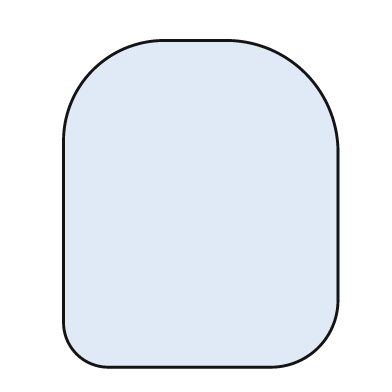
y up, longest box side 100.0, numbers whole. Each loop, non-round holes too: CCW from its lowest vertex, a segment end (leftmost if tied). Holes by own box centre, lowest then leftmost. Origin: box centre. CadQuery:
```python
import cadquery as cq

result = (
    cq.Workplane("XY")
    .moveTo(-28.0, -50.0)
    .lineTo(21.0, -50.0)
    .threePointArc((36.0, -44.0), (42.0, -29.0))
    .lineTo(42.0, 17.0)
    .threePointArc((32.0, 40.0), (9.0, 50.0))
    .lineTo(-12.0, 50.0)
    .threePointArc((-33.0, 41.0), (-42.0, 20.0))
    .lineTo(-42.0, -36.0)
    .threePointArc((-38.0, -46.0), (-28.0, -50.0))
    .close()
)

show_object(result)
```